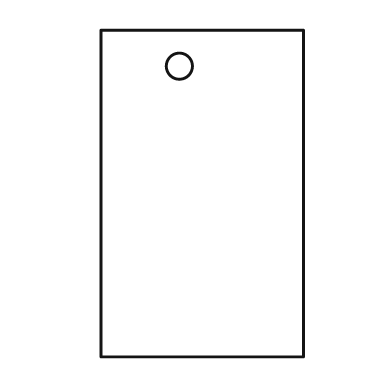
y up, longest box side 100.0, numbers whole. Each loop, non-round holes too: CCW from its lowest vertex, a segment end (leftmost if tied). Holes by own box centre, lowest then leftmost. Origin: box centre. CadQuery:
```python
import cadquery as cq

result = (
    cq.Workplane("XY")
    .moveTo(-31.0, -50.0)
    .lineTo(31.0, -50.0)
    .lineTo(31.0, 50.0)
    .lineTo(-31.0, 50.0)
    .close()
    .moveTo(-7.0, 39.0)
    .circle(4.0)
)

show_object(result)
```